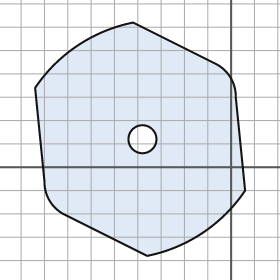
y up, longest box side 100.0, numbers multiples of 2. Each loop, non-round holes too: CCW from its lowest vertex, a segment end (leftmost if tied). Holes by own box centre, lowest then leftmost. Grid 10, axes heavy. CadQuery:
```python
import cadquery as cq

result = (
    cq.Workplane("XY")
    .moveTo(-36.0, -38.0)
    .threePointArc((-12.0, -28.0), (6.0, -10.0))
    .lineTo(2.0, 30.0)
    .threePointArc((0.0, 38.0), (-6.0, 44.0))
    .lineTo(-42.0, 62.0)
    .threePointArc((-66.0, 52.0), (-84.0, 34.0))
    .lineTo(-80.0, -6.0)
    .threePointArc((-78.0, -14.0), (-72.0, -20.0))
    .close()
    .moveTo(-38.0, 12.0)
    .circle(6.0)
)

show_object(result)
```